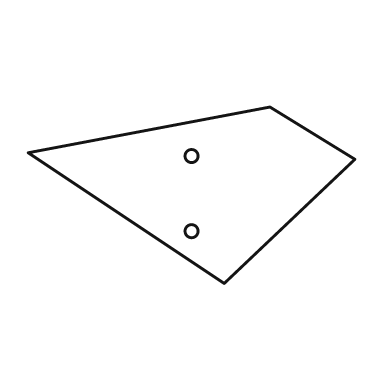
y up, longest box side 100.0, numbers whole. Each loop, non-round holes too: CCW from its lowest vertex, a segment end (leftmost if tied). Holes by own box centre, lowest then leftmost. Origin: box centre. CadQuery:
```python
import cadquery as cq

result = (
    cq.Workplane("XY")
    .moveTo(10.0, -27.0)
    .lineTo(50.0, 11.0)
    .lineTo(24.0, 27.0)
    .lineTo(-50.0, 13.0)
    .close()
    .moveTo(0.0, -11.0)
    .circle(2.0)
    .moveTo(0.0, 12.0)
    .circle(2.0)
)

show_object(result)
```